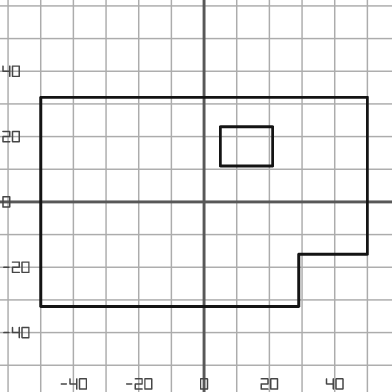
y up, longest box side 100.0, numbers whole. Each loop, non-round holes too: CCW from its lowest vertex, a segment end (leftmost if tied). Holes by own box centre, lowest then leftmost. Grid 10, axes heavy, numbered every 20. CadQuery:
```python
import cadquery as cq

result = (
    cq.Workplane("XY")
    .moveTo(-50.0, -32.0)
    .lineTo(29.0, -32.0)
    .lineTo(29.0, -16.0)
    .lineTo(50.0, -16.0)
    .lineTo(50.0, 32.0)
    .lineTo(-50.0, 32.0)
    .close()
    .moveTo(5.0, 11.0)
    .lineTo(21.0, 11.0)
    .lineTo(21.0, 23.0)
    .lineTo(5.0, 23.0)
    .close()
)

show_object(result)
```